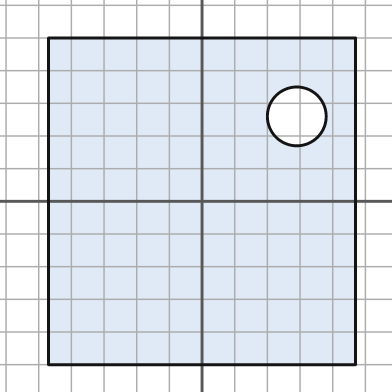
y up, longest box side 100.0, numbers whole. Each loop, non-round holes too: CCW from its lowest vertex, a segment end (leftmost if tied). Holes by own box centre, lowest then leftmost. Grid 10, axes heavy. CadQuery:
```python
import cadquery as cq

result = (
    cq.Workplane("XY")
    .moveTo(-47.0, -50.0)
    .lineTo(47.0, -50.0)
    .lineTo(47.0, 50.0)
    .lineTo(-47.0, 50.0)
    .close()
    .moveTo(29.0, 26.0)
    .circle(9.0)
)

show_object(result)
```